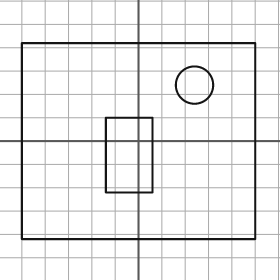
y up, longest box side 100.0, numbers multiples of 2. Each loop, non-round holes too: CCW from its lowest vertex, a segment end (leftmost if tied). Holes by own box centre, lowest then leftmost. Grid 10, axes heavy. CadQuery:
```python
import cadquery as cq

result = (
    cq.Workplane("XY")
    .moveTo(-50.0, -42.0)
    .lineTo(50.0, -42.0)
    .lineTo(50.0, 42.0)
    .lineTo(-50.0, 42.0)
    .close()
    .moveTo(-14.0, -22.0)
    .lineTo(6.0, -22.0)
    .lineTo(6.0, 10.0)
    .lineTo(-14.0, 10.0)
    .close()
    .moveTo(24.0, 24.0)
    .circle(8.0)
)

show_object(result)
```